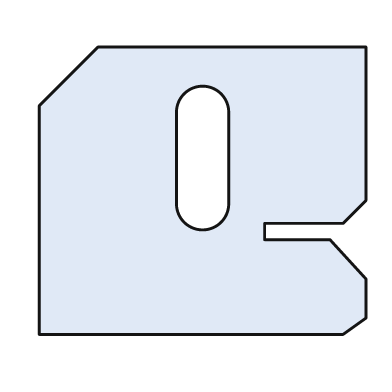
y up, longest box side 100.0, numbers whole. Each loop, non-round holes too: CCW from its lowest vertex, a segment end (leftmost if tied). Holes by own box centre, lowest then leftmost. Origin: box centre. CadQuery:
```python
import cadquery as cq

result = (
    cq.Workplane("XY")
    .moveTo(-50.0, -44.0)
    .lineTo(43.0, -44.0)
    .lineTo(50.0, -39.0)
    .lineTo(50.0, -27.0)
    .lineTo(39.0, -15.0)
    .lineTo(19.0, -15.0)
    .lineTo(19.0, -10.0)
    .lineTo(43.0, -10.0)
    .lineTo(50.0, -3.0)
    .lineTo(50.0, 44.0)
    .lineTo(-32.0, 44.0)
    .lineTo(-50.0, 26.0)
    .close()
    .moveTo(-8.0, -4.0)
    .threePointArc((0.0, -12.0), (8.0, -4.0))
    .lineTo(8.0, 24.0)
    .threePointArc((0.0, 32.0), (-8.0, 24.0))
    .close()
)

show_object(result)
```